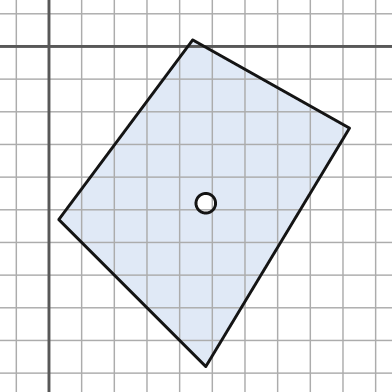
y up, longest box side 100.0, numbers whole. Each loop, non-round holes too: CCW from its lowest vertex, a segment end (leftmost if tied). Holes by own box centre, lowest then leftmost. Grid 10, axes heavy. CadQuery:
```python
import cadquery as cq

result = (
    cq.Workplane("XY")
    .moveTo(48.0, -98.0)
    .lineTo(92.0, -25.0)
    .lineTo(44.0, 2.0)
    .lineTo(3.0, -53.0)
    .close()
    .moveTo(48.0, -48.0)
    .circle(3.0)
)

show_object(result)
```